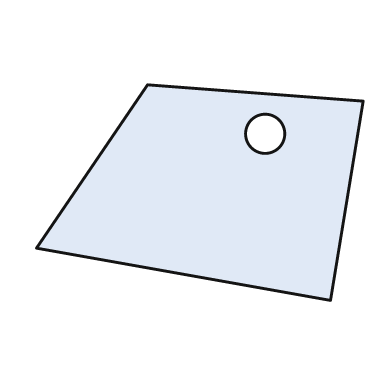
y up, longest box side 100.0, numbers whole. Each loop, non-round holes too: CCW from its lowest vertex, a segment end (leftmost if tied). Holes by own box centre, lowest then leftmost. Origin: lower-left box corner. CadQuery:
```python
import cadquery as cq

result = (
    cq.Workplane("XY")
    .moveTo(90.0, 0.0)
    .lineTo(100.0, 61.0)
    .lineTo(34.0, 66.0)
    .lineTo(0.0, 16.0)
    .close()
    .moveTo(70.0, 51.0)
    .circle(6.0)
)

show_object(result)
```